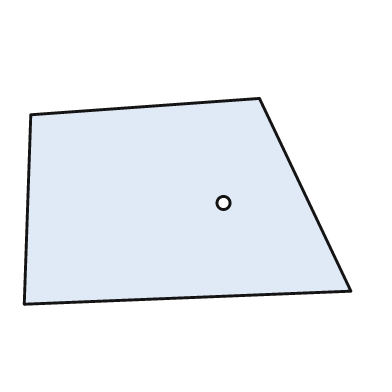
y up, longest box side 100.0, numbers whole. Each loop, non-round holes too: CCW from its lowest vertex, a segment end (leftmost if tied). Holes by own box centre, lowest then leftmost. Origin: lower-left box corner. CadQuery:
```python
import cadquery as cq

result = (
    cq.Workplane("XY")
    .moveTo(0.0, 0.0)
    .lineTo(100.0, 4.0)
    .lineTo(72.0, 63.0)
    .lineTo(2.0, 58.0)
    .close()
    .moveTo(61.0, 31.0)
    .circle(2.0)
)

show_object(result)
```